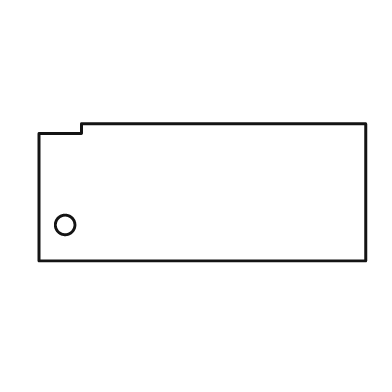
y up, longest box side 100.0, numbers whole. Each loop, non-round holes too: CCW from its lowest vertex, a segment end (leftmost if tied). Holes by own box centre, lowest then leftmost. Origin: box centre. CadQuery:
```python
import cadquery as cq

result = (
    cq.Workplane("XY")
    .moveTo(-50.0, -21.0)
    .lineTo(50.0, -21.0)
    .lineTo(50.0, 21.0)
    .lineTo(-37.0, 21.0)
    .lineTo(-37.0, 18.0)
    .lineTo(-50.0, 18.0)
    .close()
    .moveTo(-42.0, -10.0)
    .circle(3.0)
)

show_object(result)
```